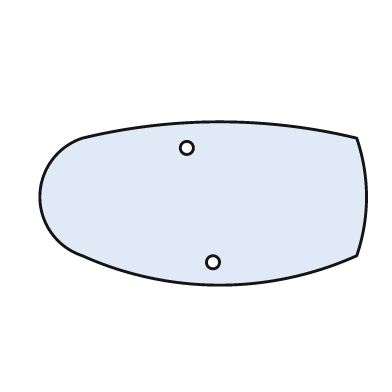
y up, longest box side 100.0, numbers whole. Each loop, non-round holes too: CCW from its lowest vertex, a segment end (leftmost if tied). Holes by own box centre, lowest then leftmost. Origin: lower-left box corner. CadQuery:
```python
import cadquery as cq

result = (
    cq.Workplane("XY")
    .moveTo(13.0, 9.0)
    .threePointArc((55.0, 0.0), (97.0, 9.0))
    .threePointArc((100.0, 27.0), (97.0, 45.0))
    .threePointArc((55.0, 50.0), (13.0, 45.0))
    .threePointArc((0.0, 27.0), (13.0, 9.0))
    .close()
    .moveTo(53.0, 7.0)
    .circle(2.0)
    .moveTo(45.0, 42.0)
    .circle(2.0)
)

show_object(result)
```